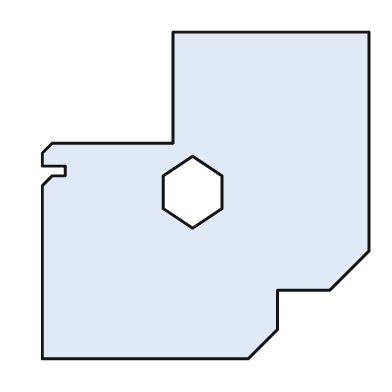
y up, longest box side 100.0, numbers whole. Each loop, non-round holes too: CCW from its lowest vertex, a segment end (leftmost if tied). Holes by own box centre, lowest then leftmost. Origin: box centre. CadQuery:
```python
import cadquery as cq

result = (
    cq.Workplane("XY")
    .moveTo(-50.0, -50.0)
    .lineTo(13.0, -50.0)
    .lineTo(22.0, -41.0)
    .lineTo(22.0, -29.0)
    .lineTo(38.0, -29.0)
    .lineTo(50.0, -17.0)
    .lineTo(50.0, 50.0)
    .lineTo(-10.0, 50.0)
    .lineTo(-10.0, 16.0)
    .lineTo(-47.0, 16.0)
    .lineTo(-50.0, 13.0)
    .lineTo(-50.0, 9.0)
    .lineTo(-43.0, 9.0)
    .lineTo(-43.0, 6.0)
    .lineTo(-47.0, 6.0)
    .lineTo(-50.0, 3.0)
    .close()
    .moveTo(-4.0, -10.0)
    .lineTo(5.0, -4.0)
    .lineTo(5.0, 6.0)
    .lineTo(-4.0, 12.0)
    .lineTo(-13.0, 6.0)
    .lineTo(-13.0, -4.0)
    .close()
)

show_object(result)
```